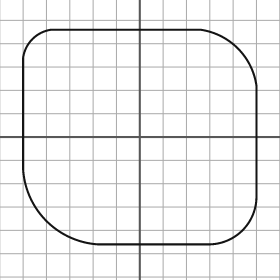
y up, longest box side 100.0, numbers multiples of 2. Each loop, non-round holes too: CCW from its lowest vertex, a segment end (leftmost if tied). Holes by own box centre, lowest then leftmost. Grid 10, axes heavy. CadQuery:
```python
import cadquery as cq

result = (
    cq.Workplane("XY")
    .moveTo(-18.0, -46.0)
    .lineTo(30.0, -46.0)
    .threePointArc((44.0, -40.0), (50.0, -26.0))
    .lineTo(50.0, 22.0)
    .threePointArc((42.0, 38.0), (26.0, 46.0))
    .lineTo(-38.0, 46.0)
    .threePointArc((-46.0, 42.0), (-50.0, 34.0))
    .lineTo(-50.0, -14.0)
    .threePointArc((-40.0, -36.0), (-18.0, -46.0))
    .close()
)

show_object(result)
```